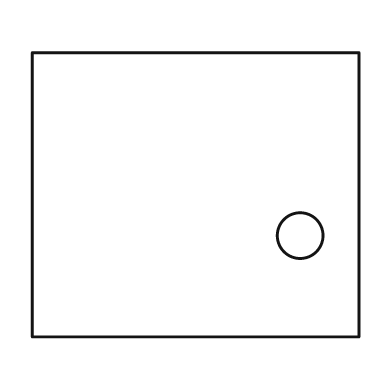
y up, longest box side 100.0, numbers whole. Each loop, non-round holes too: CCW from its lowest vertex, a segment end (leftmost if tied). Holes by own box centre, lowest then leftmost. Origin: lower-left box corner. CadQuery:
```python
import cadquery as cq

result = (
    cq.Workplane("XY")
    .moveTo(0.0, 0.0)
    .lineTo(100.0, 0.0)
    .lineTo(100.0, 87.0)
    .lineTo(0.0, 87.0)
    .close()
    .moveTo(82.0, 31.0)
    .circle(7.0)
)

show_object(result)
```